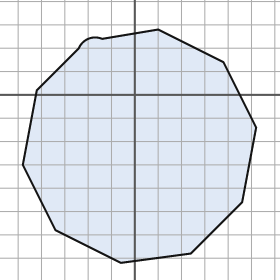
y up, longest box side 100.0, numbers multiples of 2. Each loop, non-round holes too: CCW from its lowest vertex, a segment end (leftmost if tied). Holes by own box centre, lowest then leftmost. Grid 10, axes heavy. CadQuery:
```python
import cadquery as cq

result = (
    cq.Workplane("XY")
    .moveTo(-6.0, -72.0)
    .lineTo(24.0, -68.0)
    .lineTo(46.0, -46.0)
    .lineTo(52.0, -14.0)
    .lineTo(38.0, 14.0)
    .lineTo(10.0, 28.0)
    .lineTo(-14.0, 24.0)
    .threePointArc((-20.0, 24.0), (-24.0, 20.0))
    .lineTo(-42.0, 2.0)
    .lineTo(-48.0, -30.0)
    .lineTo(-34.0, -58.0)
    .close()
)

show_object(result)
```